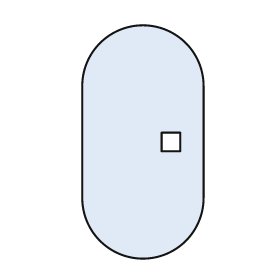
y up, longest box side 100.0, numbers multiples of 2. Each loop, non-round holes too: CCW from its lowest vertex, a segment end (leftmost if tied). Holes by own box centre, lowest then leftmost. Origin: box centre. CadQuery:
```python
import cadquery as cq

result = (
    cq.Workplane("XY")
    .moveTo(-26.0, -24.0)
    .threePointArc((0.0, -50.0), (26.0, -24.0))
    .lineTo(26.0, 24.0)
    .threePointArc((0.0, 50.0), (-26.0, 24.0))
    .close()
    .moveTo(8.0, -4.0)
    .lineTo(16.0, -4.0)
    .lineTo(16.0, 4.0)
    .lineTo(8.0, 4.0)
    .close()
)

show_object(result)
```